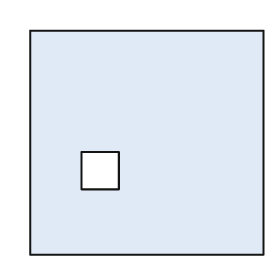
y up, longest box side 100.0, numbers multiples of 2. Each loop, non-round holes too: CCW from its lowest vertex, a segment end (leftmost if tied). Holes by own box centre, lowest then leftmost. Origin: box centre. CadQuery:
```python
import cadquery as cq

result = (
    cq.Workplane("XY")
    .moveTo(-50.0, -48.0)
    .lineTo(50.0, -48.0)
    .lineTo(50.0, 48.0)
    .lineTo(-50.0, 48.0)
    .close()
    .moveTo(-28.0, -20.0)
    .lineTo(-12.0, -20.0)
    .lineTo(-12.0, -4.0)
    .lineTo(-28.0, -4.0)
    .close()
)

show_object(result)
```